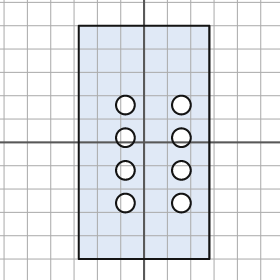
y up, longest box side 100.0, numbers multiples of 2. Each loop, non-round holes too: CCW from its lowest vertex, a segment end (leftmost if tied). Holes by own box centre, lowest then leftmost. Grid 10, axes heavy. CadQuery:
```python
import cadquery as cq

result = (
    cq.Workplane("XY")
    .moveTo(-28.0, -50.0)
    .lineTo(28.0, -50.0)
    .lineTo(28.0, 50.0)
    .lineTo(-28.0, 50.0)
    .close()
    .moveTo(-8.0, -26.0)
    .circle(4.0)
    .moveTo(16.0, -26.0)
    .circle(4.0)
    .moveTo(-8.0, -12.0)
    .circle(4.0)
    .moveTo(16.0, -12.0)
    .circle(4.0)
    .moveTo(-8.0, 2.0)
    .circle(4.0)
    .moveTo(16.0, 2.0)
    .circle(4.0)
    .moveTo(-8.0, 16.0)
    .circle(4.0)
    .moveTo(16.0, 16.0)
    .circle(4.0)
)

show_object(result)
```